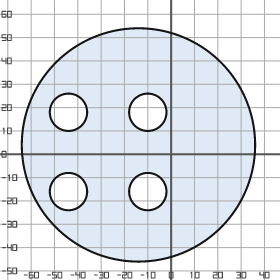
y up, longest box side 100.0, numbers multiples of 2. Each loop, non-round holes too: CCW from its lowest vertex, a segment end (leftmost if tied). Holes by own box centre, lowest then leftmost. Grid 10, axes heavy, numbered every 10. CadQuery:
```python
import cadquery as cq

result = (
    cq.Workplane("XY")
    .moveTo(-14.0, 4.0)
    .circle(50.0)
    .moveTo(-44.0, -16.0)
    .circle(8.0)
    .moveTo(-10.0, -16.0)
    .circle(8.0)
    .moveTo(-44.0, 18.0)
    .circle(8.0)
    .moveTo(-10.0, 18.0)
    .circle(8.0)
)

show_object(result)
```